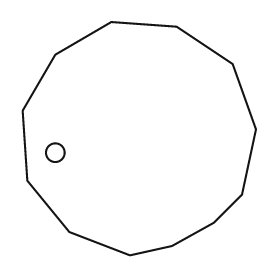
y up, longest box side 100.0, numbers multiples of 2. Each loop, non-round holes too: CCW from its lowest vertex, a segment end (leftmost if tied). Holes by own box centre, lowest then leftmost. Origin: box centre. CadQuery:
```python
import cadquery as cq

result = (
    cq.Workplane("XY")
    .moveTo(-4.0, -50.0)
    .lineTo(14.0, -46.0)
    .lineTo(32.0, -36.0)
    .lineTo(44.0, -24.0)
    .lineTo(50.0, 4.0)
    .lineTo(40.0, 32.0)
    .lineTo(16.0, 48.0)
    .lineTo(-12.0, 50.0)
    .lineTo(-36.0, 36.0)
    .lineTo(-50.0, 12.0)
    .lineTo(-48.0, -18.0)
    .lineTo(-30.0, -40.0)
    .close()
    .moveTo(-36.0, -6.0)
    .circle(4.0)
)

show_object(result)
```